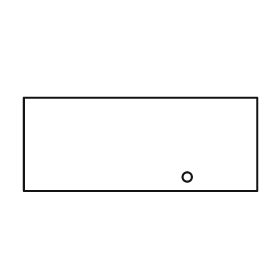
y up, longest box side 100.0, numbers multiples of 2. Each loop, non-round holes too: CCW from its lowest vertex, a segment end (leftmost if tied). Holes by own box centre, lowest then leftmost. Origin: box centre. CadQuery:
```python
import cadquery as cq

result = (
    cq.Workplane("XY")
    .moveTo(-50.0, -20.0)
    .lineTo(50.0, -20.0)
    .lineTo(50.0, 20.0)
    .lineTo(-50.0, 20.0)
    .close()
    .moveTo(20.0, -14.0)
    .circle(2.0)
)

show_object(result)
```